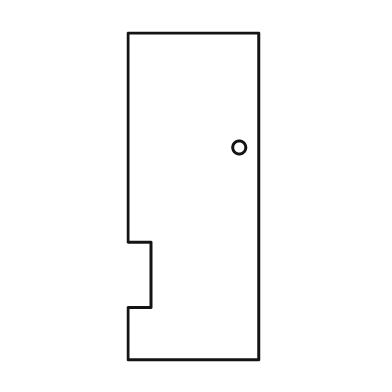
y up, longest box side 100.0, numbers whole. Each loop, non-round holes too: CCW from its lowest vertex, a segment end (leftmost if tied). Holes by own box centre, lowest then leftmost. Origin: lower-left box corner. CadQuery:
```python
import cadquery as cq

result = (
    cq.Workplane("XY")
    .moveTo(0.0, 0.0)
    .lineTo(40.0, 0.0)
    .lineTo(40.0, 100.0)
    .lineTo(0.0, 100.0)
    .lineTo(0.0, 36.0)
    .lineTo(7.0, 36.0)
    .lineTo(7.0, 16.0)
    .lineTo(0.0, 16.0)
    .close()
    .moveTo(34.0, 65.0)
    .circle(2.0)
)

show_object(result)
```